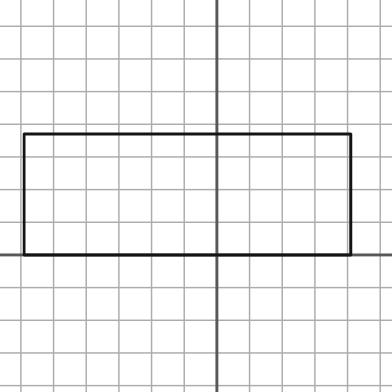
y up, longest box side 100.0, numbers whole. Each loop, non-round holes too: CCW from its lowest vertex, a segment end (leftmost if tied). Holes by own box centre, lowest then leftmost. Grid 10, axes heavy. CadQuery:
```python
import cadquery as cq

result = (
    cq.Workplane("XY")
    .moveTo(-59.0, 0.0)
    .lineTo(41.0, 0.0)
    .lineTo(41.0, 37.0)
    .lineTo(-59.0, 37.0)
    .close()
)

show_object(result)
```